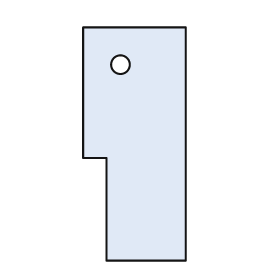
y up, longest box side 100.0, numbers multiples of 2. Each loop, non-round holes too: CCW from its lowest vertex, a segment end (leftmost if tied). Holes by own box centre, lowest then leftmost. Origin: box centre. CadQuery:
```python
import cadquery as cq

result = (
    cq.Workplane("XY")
    .moveTo(-12.0, -50.0)
    .lineTo(22.0, -50.0)
    .lineTo(22.0, 50.0)
    .lineTo(-22.0, 50.0)
    .lineTo(-22.0, -6.0)
    .lineTo(-12.0, -6.0)
    .close()
    .moveTo(-6.0, 34.0)
    .circle(4.0)
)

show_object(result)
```